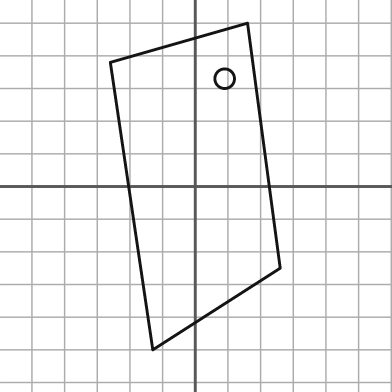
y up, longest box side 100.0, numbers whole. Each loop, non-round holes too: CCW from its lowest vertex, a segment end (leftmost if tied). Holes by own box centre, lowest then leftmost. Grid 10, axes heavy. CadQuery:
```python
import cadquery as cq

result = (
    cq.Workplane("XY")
    .moveTo(-13.0, -50.0)
    .lineTo(26.0, -25.0)
    .lineTo(16.0, 50.0)
    .lineTo(-26.0, 38.0)
    .close()
    .moveTo(9.0, 33.0)
    .circle(3.0)
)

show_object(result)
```